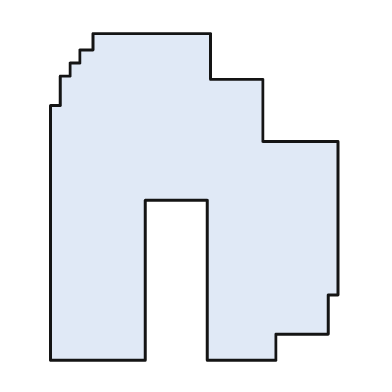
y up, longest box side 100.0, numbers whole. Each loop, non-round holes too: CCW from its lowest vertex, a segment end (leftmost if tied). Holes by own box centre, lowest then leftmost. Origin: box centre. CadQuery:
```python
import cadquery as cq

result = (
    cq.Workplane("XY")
    .moveTo(-44.0, -50.0)
    .lineTo(-15.0, -50.0)
    .lineTo(-15.0, -1.0)
    .lineTo(4.0, -1.0)
    .lineTo(4.0, -50.0)
    .lineTo(25.0, -50.0)
    .lineTo(25.0, -42.0)
    .lineTo(41.0, -42.0)
    .lineTo(41.0, -30.0)
    .lineTo(44.0, -30.0)
    .lineTo(44.0, 17.0)
    .lineTo(21.0, 17.0)
    .lineTo(21.0, 36.0)
    .lineTo(5.0, 36.0)
    .lineTo(5.0, 50.0)
    .lineTo(-31.0, 50.0)
    .lineTo(-31.0, 45.0)
    .lineTo(-35.0, 45.0)
    .lineTo(-35.0, 41.0)
    .lineTo(-38.0, 41.0)
    .lineTo(-38.0, 37.0)
    .lineTo(-41.0, 37.0)
    .lineTo(-41.0, 28.0)
    .lineTo(-44.0, 28.0)
    .close()
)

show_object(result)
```